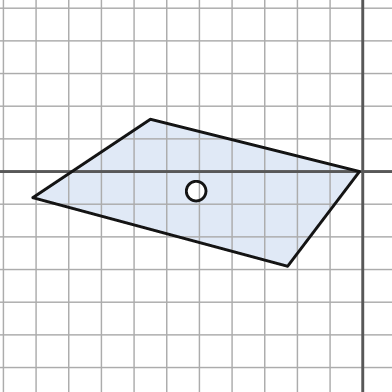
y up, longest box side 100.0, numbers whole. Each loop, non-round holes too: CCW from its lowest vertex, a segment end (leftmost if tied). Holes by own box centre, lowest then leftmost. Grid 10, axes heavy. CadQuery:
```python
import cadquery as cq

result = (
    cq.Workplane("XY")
    .moveTo(-23.0, -29.0)
    .lineTo(-1.0, 0.0)
    .lineTo(-65.0, 16.0)
    .lineTo(-101.0, -8.0)
    .close()
    .moveTo(-51.0, -6.0)
    .circle(3.0)
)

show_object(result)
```